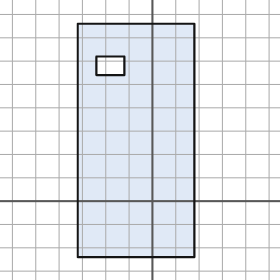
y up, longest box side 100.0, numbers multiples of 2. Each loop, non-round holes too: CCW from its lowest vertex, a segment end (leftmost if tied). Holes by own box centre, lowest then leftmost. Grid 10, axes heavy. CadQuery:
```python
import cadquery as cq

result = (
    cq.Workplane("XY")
    .moveTo(-32.0, -24.0)
    .lineTo(18.0, -24.0)
    .lineTo(18.0, 76.0)
    .lineTo(-32.0, 76.0)
    .close()
    .moveTo(-24.0, 54.0)
    .lineTo(-12.0, 54.0)
    .lineTo(-12.0, 62.0)
    .lineTo(-24.0, 62.0)
    .close()
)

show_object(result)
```